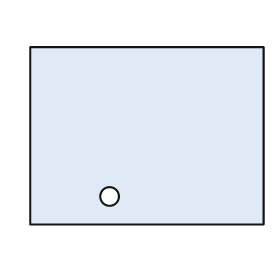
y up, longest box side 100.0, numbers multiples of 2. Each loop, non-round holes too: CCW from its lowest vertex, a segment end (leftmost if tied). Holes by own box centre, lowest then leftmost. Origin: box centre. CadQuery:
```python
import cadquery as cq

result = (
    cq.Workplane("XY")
    .moveTo(-50.0, -38.0)
    .lineTo(50.0, -38.0)
    .lineTo(50.0, 38.0)
    .lineTo(-50.0, 38.0)
    .close()
    .moveTo(-16.0, -26.0)
    .circle(4.0)
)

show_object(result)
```